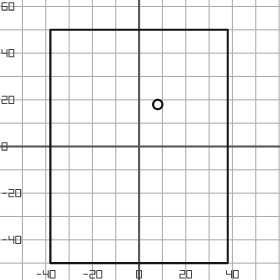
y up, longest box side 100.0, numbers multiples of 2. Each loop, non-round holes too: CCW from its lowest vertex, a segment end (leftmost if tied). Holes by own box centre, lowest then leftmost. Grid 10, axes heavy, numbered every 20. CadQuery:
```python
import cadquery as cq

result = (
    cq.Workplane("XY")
    .moveTo(-38.0, -50.0)
    .lineTo(38.0, -50.0)
    .lineTo(38.0, 50.0)
    .lineTo(-38.0, 50.0)
    .close()
    .moveTo(8.0, 18.0)
    .circle(2.0)
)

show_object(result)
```